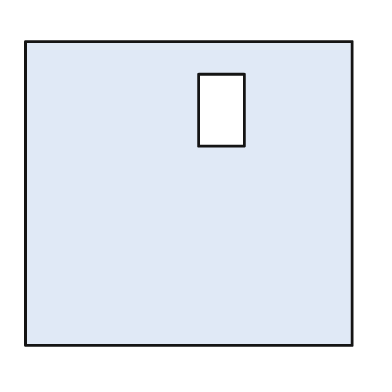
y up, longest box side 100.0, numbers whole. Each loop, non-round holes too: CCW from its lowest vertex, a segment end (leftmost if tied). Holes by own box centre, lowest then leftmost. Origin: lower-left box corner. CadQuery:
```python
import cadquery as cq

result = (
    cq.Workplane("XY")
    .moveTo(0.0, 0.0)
    .lineTo(100.0, 0.0)
    .lineTo(100.0, 93.0)
    .lineTo(0.0, 93.0)
    .close()
    .moveTo(53.0, 61.0)
    .lineTo(67.0, 61.0)
    .lineTo(67.0, 83.0)
    .lineTo(53.0, 83.0)
    .close()
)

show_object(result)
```